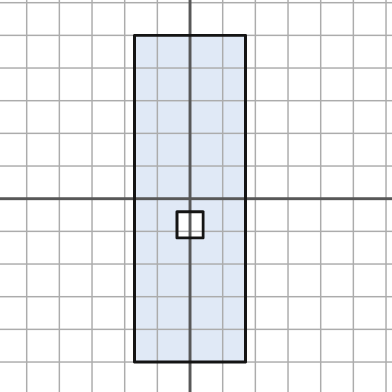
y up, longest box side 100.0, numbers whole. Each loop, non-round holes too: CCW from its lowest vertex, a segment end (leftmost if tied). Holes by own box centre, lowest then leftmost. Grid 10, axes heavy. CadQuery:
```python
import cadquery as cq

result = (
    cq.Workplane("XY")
    .moveTo(-17.0, -50.0)
    .lineTo(17.0, -50.0)
    .lineTo(17.0, 50.0)
    .lineTo(-17.0, 50.0)
    .close()
    .moveTo(-4.0, -12.0)
    .lineTo(4.0, -12.0)
    .lineTo(4.0, -4.0)
    .lineTo(-4.0, -4.0)
    .close()
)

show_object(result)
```